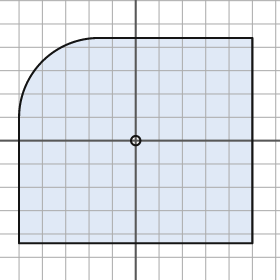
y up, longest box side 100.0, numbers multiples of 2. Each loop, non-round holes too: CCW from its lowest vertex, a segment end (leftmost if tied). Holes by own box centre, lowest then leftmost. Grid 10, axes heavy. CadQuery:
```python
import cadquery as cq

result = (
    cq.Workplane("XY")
    .moveTo(-50.0, -44.0)
    .lineTo(50.0, -44.0)
    .lineTo(50.0, 44.0)
    .lineTo(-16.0, 44.0)
    .threePointArc((-40.0, 34.0), (-50.0, 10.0))
    .close()
    .moveTo(0.0, 0.0)
    .circle(2.0)
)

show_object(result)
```